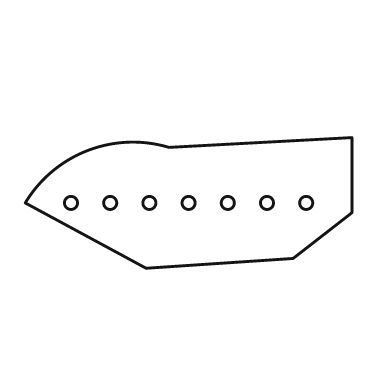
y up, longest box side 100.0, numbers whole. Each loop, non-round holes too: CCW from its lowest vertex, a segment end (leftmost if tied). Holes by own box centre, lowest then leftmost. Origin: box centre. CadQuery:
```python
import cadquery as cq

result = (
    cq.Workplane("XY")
    .moveTo(-13.0, -20.0)
    .lineTo(32.0, -17.0)
    .lineTo(50.0, -3.0)
    .lineTo(50.0, 20.0)
    .lineTo(-6.0, 17.0)
    .threePointArc((-31.0, 16.0), (-50.0, 0.0))
    .close()
    .moveTo(-36.0, 0.0)
    .circle(2.0)
    .moveTo(-24.0, 0.0)
    .circle(2.0)
    .moveTo(-12.0, 0.0)
    .circle(2.0)
    .moveTo(0.0, 0.0)
    .circle(2.0)
    .moveTo(12.0, 0.0)
    .circle(2.0)
    .moveTo(24.0, 0.0)
    .circle(2.0)
    .moveTo(36.0, 0.0)
    .circle(2.0)
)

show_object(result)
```